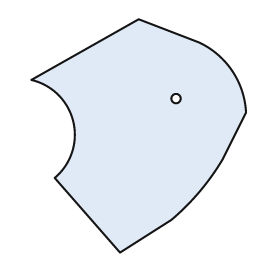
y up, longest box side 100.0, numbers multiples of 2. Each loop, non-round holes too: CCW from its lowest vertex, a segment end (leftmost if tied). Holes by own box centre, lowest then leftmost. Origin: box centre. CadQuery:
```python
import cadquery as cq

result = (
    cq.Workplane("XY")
    .moveTo(-8.0, -50.0)
    .lineTo(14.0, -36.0)
    .threePointArc((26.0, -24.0), (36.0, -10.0))
    .lineTo(46.0, 10.0)
    .threePointArc((40.0, 28.0), (26.0, 40.0))
    .lineTo(0.0, 50.0)
    .lineTo(-46.0, 24.0)
    .threePointArc((-28.0, 6.0), (-36.0, -18.0))
    .close()
    .moveTo(16.0, 16.0)
    .circle(2.0)
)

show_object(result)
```